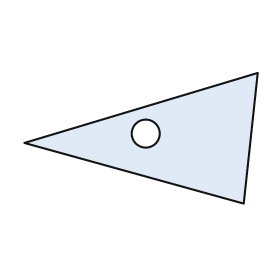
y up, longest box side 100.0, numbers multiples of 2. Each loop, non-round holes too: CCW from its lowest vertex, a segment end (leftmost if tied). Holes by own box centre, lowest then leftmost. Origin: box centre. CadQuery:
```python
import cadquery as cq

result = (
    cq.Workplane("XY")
    .moveTo(44.0, -28.0)
    .lineTo(50.0, 28.0)
    .lineTo(-50.0, -2.0)
    .close()
    .moveTo(2.0, 2.0)
    .circle(6.0)
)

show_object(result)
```